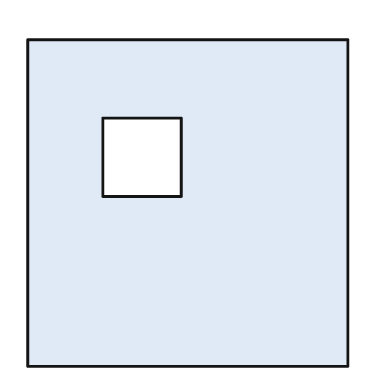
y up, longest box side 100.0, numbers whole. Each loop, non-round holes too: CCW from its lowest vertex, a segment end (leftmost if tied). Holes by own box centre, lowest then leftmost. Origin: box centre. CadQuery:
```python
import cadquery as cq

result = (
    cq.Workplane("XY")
    .moveTo(-49.0, -50.0)
    .lineTo(49.0, -50.0)
    .lineTo(49.0, 50.0)
    .lineTo(-49.0, 50.0)
    .close()
    .moveTo(-26.0, 2.0)
    .lineTo(-2.0, 2.0)
    .lineTo(-2.0, 26.0)
    .lineTo(-26.0, 26.0)
    .close()
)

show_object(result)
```